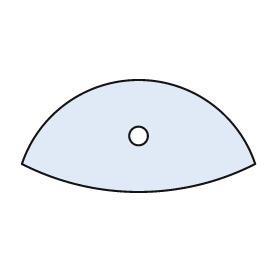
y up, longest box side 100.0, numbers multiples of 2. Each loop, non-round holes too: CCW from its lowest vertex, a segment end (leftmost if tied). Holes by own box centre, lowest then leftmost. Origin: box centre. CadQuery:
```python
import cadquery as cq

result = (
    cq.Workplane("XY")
    .moveTo(-50.0, -12.0)
    .threePointArc((0.0, -24.0), (50.0, -12.0))
    .threePointArc((0.0, 24.0), (-50.0, -12.0))
    .close()
    .moveTo(0.0, 0.0)
    .circle(4.0)
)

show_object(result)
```